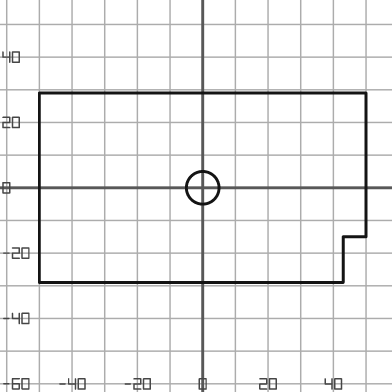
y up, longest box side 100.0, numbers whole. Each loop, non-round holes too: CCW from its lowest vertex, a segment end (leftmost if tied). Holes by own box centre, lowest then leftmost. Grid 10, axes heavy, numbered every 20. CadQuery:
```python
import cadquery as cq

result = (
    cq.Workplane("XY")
    .moveTo(-50.0, -29.0)
    .lineTo(43.0, -29.0)
    .lineTo(43.0, -15.0)
    .lineTo(50.0, -15.0)
    .lineTo(50.0, 29.0)
    .lineTo(-50.0, 29.0)
    .close()
    .moveTo(0.0, 0.0)
    .circle(5.0)
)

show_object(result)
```